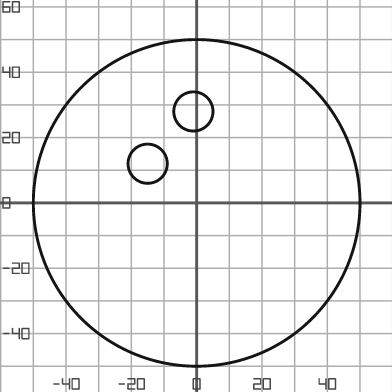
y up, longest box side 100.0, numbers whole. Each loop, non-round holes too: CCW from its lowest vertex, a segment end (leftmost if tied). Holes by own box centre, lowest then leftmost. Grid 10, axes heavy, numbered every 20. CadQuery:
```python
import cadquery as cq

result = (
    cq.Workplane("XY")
    .moveTo(0.0, 0.0)
    .circle(50.0)
    .moveTo(-15.0, 12.0)
    .circle(6.0)
    .moveTo(-1.0, 28.0)
    .circle(6.0)
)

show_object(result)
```